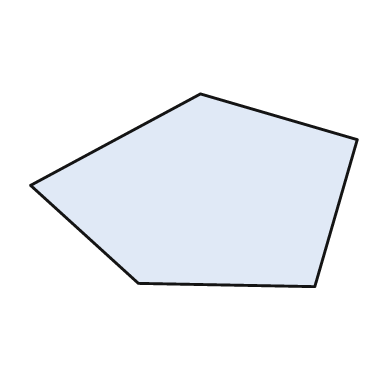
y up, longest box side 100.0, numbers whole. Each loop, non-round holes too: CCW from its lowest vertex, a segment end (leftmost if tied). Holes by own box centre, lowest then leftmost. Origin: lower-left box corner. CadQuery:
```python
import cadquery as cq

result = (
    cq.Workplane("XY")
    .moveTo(87.0, 0.0)
    .lineTo(100.0, 45.0)
    .lineTo(52.0, 59.0)
    .lineTo(0.0, 31.0)
    .lineTo(33.0, 1.0)
    .close()
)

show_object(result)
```